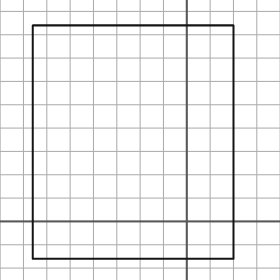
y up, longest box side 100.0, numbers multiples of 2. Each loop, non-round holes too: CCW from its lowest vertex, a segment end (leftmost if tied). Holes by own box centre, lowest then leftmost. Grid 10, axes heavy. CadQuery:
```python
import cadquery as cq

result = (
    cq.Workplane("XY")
    .moveTo(-66.0, -16.0)
    .lineTo(20.0, -16.0)
    .lineTo(20.0, 84.0)
    .lineTo(-66.0, 84.0)
    .close()
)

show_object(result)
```